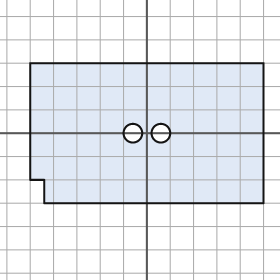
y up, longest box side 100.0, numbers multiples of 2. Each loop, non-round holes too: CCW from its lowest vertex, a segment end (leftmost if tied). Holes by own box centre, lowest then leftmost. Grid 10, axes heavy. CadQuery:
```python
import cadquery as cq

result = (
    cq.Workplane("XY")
    .moveTo(-44.0, -30.0)
    .lineTo(50.0, -30.0)
    .lineTo(50.0, 30.0)
    .lineTo(-50.0, 30.0)
    .lineTo(-50.0, -20.0)
    .lineTo(-44.0, -20.0)
    .close()
    .moveTo(-6.0, 0.0)
    .circle(4.0)
    .moveTo(6.0, 0.0)
    .circle(4.0)
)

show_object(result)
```